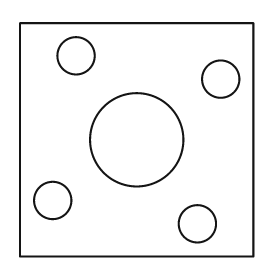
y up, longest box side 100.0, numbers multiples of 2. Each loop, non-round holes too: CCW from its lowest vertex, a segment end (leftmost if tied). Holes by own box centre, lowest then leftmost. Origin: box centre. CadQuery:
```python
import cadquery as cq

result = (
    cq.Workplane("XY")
    .moveTo(-50.0, -50.0)
    .lineTo(50.0, -50.0)
    .lineTo(50.0, 50.0)
    .lineTo(-50.0, 50.0)
    .close()
    .moveTo(26.0, -36.0)
    .circle(8.0)
    .moveTo(-36.0, -26.0)
    .circle(8.0)
    .moveTo(0.0, 0.0)
    .circle(20.0)
    .moveTo(36.0, 26.0)
    .circle(8.0)
    .moveTo(-26.0, 36.0)
    .circle(8.0)
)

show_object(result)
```